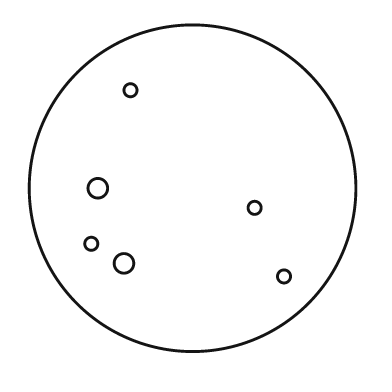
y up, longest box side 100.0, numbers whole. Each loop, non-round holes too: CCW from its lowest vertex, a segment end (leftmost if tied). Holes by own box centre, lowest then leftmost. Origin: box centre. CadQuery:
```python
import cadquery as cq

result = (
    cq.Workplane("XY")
    .moveTo(0.0, 0.0)
    .circle(50.0)
    .moveTo(28.0, -27.0)
    .circle(2.0)
    .moveTo(-21.0, -23.0)
    .circle(3.0)
    .moveTo(-31.0, -17.0)
    .circle(2.0)
    .moveTo(19.0, -6.0)
    .circle(2.0)
    .moveTo(-29.0, 0.0)
    .circle(3.0)
    .moveTo(-19.0, 30.0)
    .circle(2.0)
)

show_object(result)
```